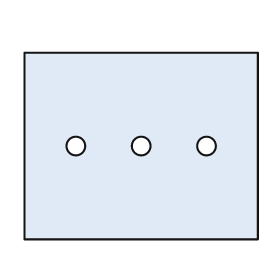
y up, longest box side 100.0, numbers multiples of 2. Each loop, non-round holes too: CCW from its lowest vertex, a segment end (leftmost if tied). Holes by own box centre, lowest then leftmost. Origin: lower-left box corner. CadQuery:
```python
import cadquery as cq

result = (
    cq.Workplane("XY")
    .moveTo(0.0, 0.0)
    .lineTo(100.0, 0.0)
    .lineTo(100.0, 80.0)
    .lineTo(0.0, 80.0)
    .close()
    .moveTo(22.0, 40.0)
    .circle(4.0)
    .moveTo(50.0, 40.0)
    .circle(4.0)
    .moveTo(78.0, 40.0)
    .circle(4.0)
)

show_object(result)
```